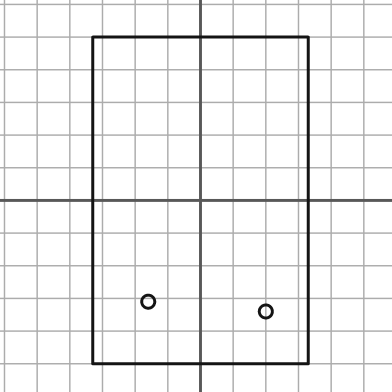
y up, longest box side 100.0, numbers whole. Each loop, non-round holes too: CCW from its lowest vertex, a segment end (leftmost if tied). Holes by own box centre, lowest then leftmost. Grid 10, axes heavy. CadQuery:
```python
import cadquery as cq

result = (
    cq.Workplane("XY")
    .moveTo(-33.0, -50.0)
    .lineTo(33.0, -50.0)
    .lineTo(33.0, 50.0)
    .lineTo(-33.0, 50.0)
    .close()
    .moveTo(20.0, -34.0)
    .circle(2.0)
    .moveTo(-16.0, -31.0)
    .circle(2.0)
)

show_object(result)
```